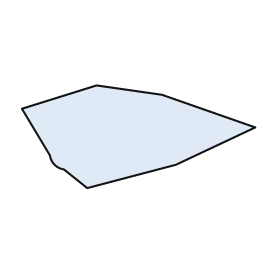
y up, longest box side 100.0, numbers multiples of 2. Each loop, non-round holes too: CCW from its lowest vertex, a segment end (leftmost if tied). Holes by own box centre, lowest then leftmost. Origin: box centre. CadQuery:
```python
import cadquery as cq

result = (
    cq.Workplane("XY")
    .moveTo(-22.0, -22.0)
    .lineTo(16.0, -12.0)
    .lineTo(50.0, 4.0)
    .lineTo(10.0, 18.0)
    .lineTo(-18.0, 22.0)
    .lineTo(-50.0, 12.0)
    .lineTo(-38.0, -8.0)
    .threePointArc((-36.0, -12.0), (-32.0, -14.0))
    .close()
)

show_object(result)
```